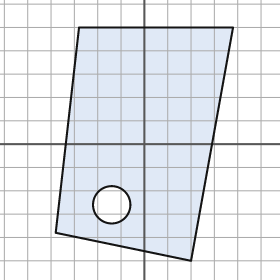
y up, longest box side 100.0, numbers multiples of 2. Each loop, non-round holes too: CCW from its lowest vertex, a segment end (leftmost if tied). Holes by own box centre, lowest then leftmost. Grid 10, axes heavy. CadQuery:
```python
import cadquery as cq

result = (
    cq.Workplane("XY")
    .moveTo(20.0, -50.0)
    .lineTo(38.0, 50.0)
    .lineTo(-28.0, 50.0)
    .lineTo(-38.0, -38.0)
    .close()
    .moveTo(-14.0, -26.0)
    .circle(8.0)
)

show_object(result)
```